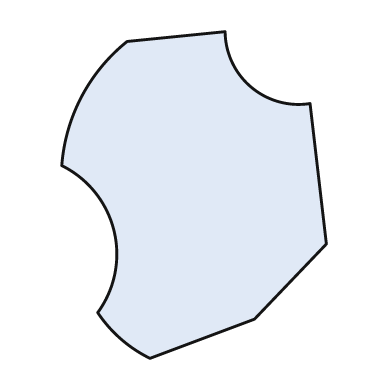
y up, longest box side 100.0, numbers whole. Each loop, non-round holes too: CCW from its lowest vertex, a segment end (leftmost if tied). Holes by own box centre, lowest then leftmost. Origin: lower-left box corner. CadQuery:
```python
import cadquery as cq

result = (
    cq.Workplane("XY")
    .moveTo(27.0, 0.0)
    .lineTo(59.0, 12.0)
    .lineTo(81.0, 35.0)
    .lineTo(76.0, 78.0)
    .threePointArc((58.0, 83.0), (50.0, 100.0))
    .lineTo(20.0, 97.0)
    .threePointArc((6.0, 80.0), (0.0, 59.0))
    .threePointArc((16.0, 39.0), (11.0, 14.0))
    .threePointArc((18.0, 6.0), (27.0, 0.0))
    .close()
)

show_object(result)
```